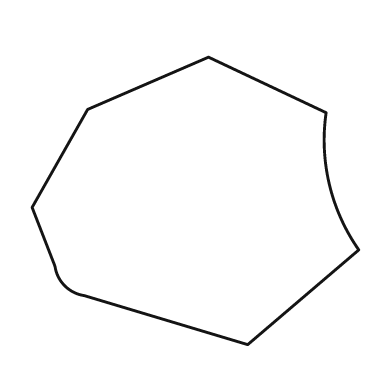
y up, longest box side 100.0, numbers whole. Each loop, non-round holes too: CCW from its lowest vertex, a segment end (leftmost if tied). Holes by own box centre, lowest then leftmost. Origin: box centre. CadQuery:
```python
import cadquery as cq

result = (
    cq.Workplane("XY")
    .moveTo(16.0, -44.0)
    .lineTo(50.0, -15.0)
    .threePointArc((41.0, 5.0), (40.0, 27.0))
    .lineTo(4.0, 44.0)
    .lineTo(-33.0, 28.0)
    .lineTo(-50.0, -2.0)
    .lineTo(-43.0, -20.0)
    .threePointArc((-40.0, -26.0), (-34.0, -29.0))
    .close()
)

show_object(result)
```